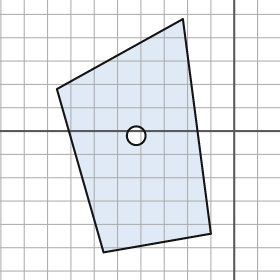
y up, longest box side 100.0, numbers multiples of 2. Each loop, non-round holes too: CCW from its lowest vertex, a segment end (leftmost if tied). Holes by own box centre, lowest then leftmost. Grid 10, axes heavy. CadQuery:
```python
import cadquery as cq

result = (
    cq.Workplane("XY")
    .moveTo(-56.0, -52.0)
    .lineTo(-10.0, -44.0)
    .lineTo(-22.0, 48.0)
    .lineTo(-76.0, 18.0)
    .close()
    .moveTo(-42.0, -2.0)
    .circle(4.0)
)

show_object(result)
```